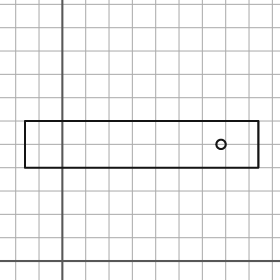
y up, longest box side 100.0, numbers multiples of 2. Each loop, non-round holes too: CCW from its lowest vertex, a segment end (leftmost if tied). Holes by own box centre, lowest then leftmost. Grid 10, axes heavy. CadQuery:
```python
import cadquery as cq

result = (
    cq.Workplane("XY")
    .moveTo(-16.0, 40.0)
    .lineTo(84.0, 40.0)
    .lineTo(84.0, 60.0)
    .lineTo(-16.0, 60.0)
    .close()
    .moveTo(68.0, 50.0)
    .circle(2.0)
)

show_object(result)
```